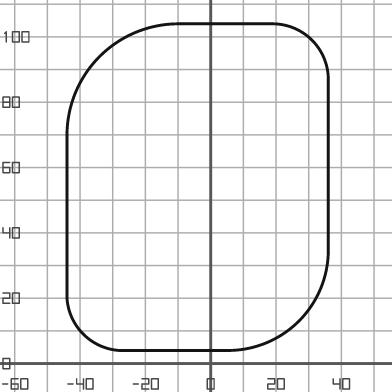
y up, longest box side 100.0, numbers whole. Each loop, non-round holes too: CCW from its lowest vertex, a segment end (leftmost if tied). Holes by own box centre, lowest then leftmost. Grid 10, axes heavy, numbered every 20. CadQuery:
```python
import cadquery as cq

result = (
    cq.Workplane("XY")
    .moveTo(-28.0, 4.0)
    .lineTo(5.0, 4.0)
    .threePointArc((27.0, 13.0), (36.0, 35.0))
    .lineTo(36.0, 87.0)
    .threePointArc((31.0, 99.0), (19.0, 104.0))
    .lineTo(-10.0, 104.0)
    .threePointArc((-34.0, 94.0), (-44.0, 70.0))
    .lineTo(-44.0, 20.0)
    .threePointArc((-39.0, 9.0), (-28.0, 4.0))
    .close()
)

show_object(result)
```